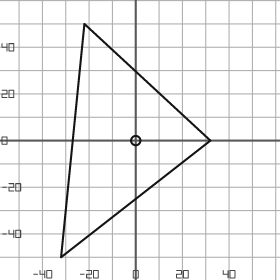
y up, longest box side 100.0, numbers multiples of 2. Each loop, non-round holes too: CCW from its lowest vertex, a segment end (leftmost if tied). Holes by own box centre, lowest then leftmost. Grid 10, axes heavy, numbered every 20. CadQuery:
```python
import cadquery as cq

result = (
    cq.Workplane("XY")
    .moveTo(-32.0, -50.0)
    .lineTo(32.0, 0.0)
    .lineTo(-22.0, 50.0)
    .close()
    .moveTo(0.0, 0.0)
    .circle(2.0)
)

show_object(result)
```